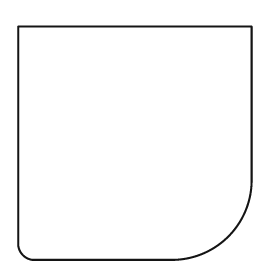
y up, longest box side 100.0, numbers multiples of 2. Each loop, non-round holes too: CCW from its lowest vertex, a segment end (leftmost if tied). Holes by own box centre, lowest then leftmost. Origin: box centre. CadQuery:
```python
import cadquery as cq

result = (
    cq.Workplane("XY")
    .moveTo(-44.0, -50.0)
    .lineTo(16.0, -50.0)
    .threePointArc((40.0, -40.0), (50.0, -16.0))
    .lineTo(50.0, 50.0)
    .lineTo(-50.0, 50.0)
    .lineTo(-50.0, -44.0)
    .threePointArc((-48.0, -48.0), (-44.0, -50.0))
    .close()
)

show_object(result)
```